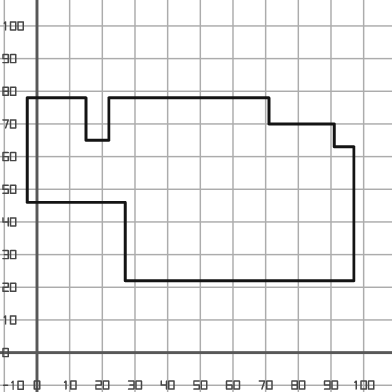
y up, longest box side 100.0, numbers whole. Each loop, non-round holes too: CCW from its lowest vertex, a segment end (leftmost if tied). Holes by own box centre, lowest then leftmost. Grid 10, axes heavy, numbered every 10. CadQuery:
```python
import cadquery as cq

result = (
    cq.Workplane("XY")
    .moveTo(27.0, 22.0)
    .lineTo(97.0, 22.0)
    .lineTo(97.0, 63.0)
    .lineTo(91.0, 63.0)
    .lineTo(91.0, 70.0)
    .lineTo(71.0, 70.0)
    .lineTo(71.0, 78.0)
    .lineTo(22.0, 78.0)
    .lineTo(22.0, 65.0)
    .lineTo(15.0, 65.0)
    .lineTo(15.0, 78.0)
    .lineTo(-3.0, 78.0)
    .lineTo(-3.0, 46.0)
    .lineTo(27.0, 46.0)
    .close()
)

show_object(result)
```